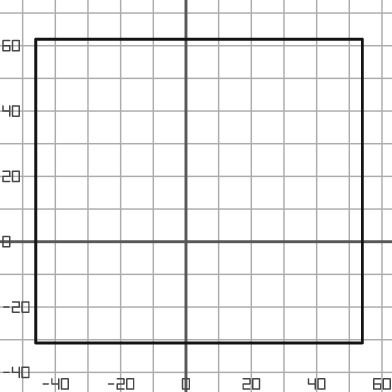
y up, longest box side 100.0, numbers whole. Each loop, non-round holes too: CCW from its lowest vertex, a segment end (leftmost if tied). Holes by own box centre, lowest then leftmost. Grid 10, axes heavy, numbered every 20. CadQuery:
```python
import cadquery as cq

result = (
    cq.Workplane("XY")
    .moveTo(-46.0, -31.0)
    .lineTo(54.0, -31.0)
    .lineTo(54.0, 62.0)
    .lineTo(-46.0, 62.0)
    .close()
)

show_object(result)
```